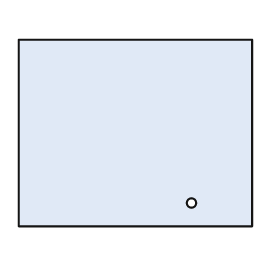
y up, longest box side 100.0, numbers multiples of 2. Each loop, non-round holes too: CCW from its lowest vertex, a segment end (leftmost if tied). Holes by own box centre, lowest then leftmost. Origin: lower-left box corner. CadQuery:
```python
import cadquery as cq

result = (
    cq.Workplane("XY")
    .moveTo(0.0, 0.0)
    .lineTo(100.0, 0.0)
    .lineTo(100.0, 80.0)
    .lineTo(0.0, 80.0)
    .close()
    .moveTo(74.0, 10.0)
    .circle(2.0)
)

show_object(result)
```